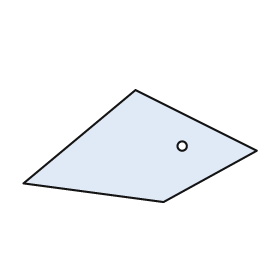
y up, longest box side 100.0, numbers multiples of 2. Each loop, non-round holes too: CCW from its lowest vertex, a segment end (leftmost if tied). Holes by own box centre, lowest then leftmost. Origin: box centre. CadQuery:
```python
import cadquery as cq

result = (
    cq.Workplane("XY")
    .moveTo(10.0, -24.0)
    .lineTo(50.0, -2.0)
    .lineTo(-2.0, 24.0)
    .lineTo(-50.0, -16.0)
    .close()
    .moveTo(18.0, 0.0)
    .circle(2.0)
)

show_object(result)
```